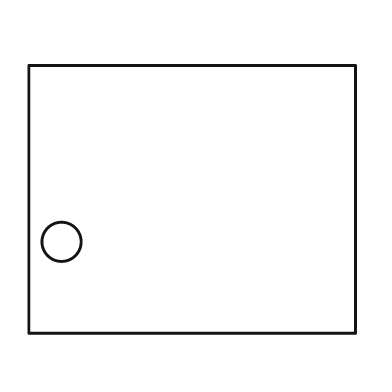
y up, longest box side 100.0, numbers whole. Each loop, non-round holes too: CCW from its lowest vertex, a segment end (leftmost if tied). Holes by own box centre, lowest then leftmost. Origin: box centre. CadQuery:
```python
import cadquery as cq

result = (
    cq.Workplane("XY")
    .moveTo(-50.0, -41.0)
    .lineTo(50.0, -41.0)
    .lineTo(50.0, 41.0)
    .lineTo(-50.0, 41.0)
    .close()
    .moveTo(-40.0, -13.0)
    .circle(6.0)
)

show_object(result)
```